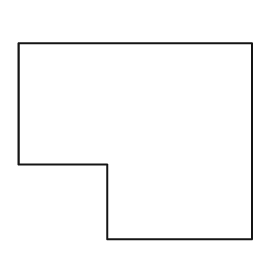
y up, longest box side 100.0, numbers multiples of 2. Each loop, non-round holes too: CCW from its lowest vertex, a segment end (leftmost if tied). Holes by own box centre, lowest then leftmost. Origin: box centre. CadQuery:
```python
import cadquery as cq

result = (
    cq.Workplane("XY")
    .moveTo(-12.0, -42.0)
    .lineTo(50.0, -42.0)
    .lineTo(50.0, 42.0)
    .lineTo(-50.0, 42.0)
    .lineTo(-50.0, -10.0)
    .lineTo(-12.0, -10.0)
    .close()
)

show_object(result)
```